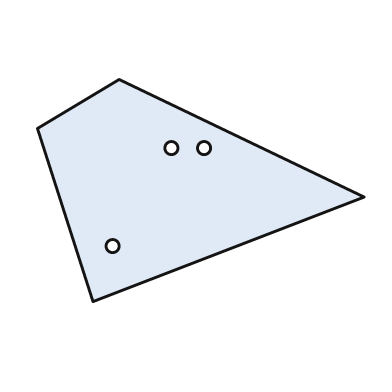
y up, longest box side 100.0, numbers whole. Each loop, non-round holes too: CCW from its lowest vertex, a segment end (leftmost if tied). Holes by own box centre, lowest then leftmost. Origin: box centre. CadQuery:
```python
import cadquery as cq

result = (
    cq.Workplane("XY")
    .moveTo(-33.0, -34.0)
    .lineTo(50.0, -2.0)
    .lineTo(-25.0, 34.0)
    .lineTo(-50.0, 19.0)
    .close()
    .moveTo(-27.0, -17.0)
    .circle(2.0)
    .moveTo(-9.0, 13.0)
    .circle(2.0)
    .moveTo(1.0, 13.0)
    .circle(2.0)
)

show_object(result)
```